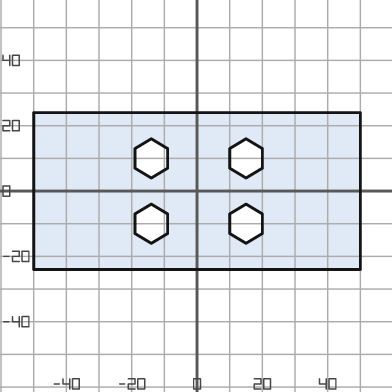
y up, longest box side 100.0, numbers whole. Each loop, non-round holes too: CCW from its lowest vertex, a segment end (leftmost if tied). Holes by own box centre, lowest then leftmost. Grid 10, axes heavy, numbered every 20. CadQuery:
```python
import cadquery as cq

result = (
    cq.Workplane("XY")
    .moveTo(-50.0, -24.0)
    .lineTo(50.0, -24.0)
    .lineTo(50.0, 24.0)
    .lineTo(-50.0, 24.0)
    .close()
    .moveTo(-14.0, -16.0)
    .lineTo(-9.0, -13.0)
    .lineTo(-9.0, -7.0)
    .lineTo(-14.0, -4.0)
    .lineTo(-19.0, -7.0)
    .lineTo(-19.0, -13.0)
    .close()
    .moveTo(15.0, -16.0)
    .lineTo(20.0, -13.0)
    .lineTo(20.0, -7.0)
    .lineTo(15.0, -4.0)
    .lineTo(10.0, -7.0)
    .lineTo(10.0, -13.0)
    .close()
    .moveTo(-14.0, 4.0)
    .lineTo(-9.0, 7.0)
    .lineTo(-9.0, 13.0)
    .lineTo(-14.0, 16.0)
    .lineTo(-19.0, 13.0)
    .lineTo(-19.0, 7.0)
    .close()
    .moveTo(15.0, 4.0)
    .lineTo(20.0, 7.0)
    .lineTo(20.0, 13.0)
    .lineTo(15.0, 16.0)
    .lineTo(10.0, 13.0)
    .lineTo(10.0, 7.0)
    .close()
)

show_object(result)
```